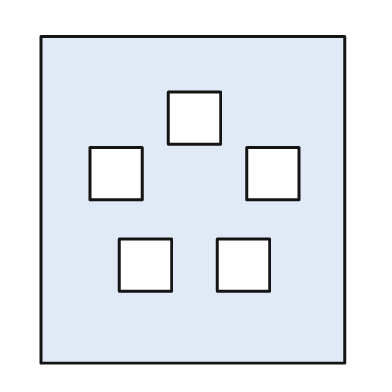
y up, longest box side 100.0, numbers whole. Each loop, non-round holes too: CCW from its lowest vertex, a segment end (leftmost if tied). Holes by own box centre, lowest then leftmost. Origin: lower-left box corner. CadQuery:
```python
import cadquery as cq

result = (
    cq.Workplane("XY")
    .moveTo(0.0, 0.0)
    .lineTo(93.0, 0.0)
    .lineTo(93.0, 100.0)
    .lineTo(0.0, 100.0)
    .close()
    .moveTo(24.0, 22.0)
    .lineTo(40.0, 22.0)
    .lineTo(40.0, 38.0)
    .lineTo(24.0, 38.0)
    .close()
    .moveTo(54.0, 22.0)
    .lineTo(70.0, 22.0)
    .lineTo(70.0, 38.0)
    .lineTo(54.0, 38.0)
    .close()
    .moveTo(15.0, 50.0)
    .lineTo(31.0, 50.0)
    .lineTo(31.0, 66.0)
    .lineTo(15.0, 66.0)
    .close()
    .moveTo(63.0, 50.0)
    .lineTo(79.0, 50.0)
    .lineTo(79.0, 66.0)
    .lineTo(63.0, 66.0)
    .close()
    .moveTo(39.0, 67.0)
    .lineTo(55.0, 67.0)
    .lineTo(55.0, 83.0)
    .lineTo(39.0, 83.0)
    .close()
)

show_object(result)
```